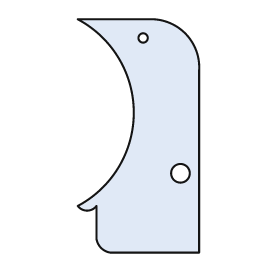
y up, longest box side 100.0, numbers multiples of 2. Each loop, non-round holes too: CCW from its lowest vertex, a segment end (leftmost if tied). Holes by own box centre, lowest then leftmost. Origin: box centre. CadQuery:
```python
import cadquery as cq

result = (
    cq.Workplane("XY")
    .moveTo(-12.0, -50.0)
    .lineTo(26.0, -50.0)
    .lineTo(26.0, 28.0)
    .threePointArc((20.0, 44.0), (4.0, 50.0))
    .lineTo(-26.0, 50.0)
    .threePointArc((-2.0, 10.0), (-26.0, -30.0))
    .threePointArc((-22.0, -32.0), (-18.0, -30.0))
    .lineTo(-18.0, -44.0)
    .threePointArc((-16.0, -48.0), (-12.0, -50.0))
    .close()
    .moveTo(18.0, -16.0)
    .circle(4.0)
    .moveTo(2.0, 42.0)
    .circle(2.0)
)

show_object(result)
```